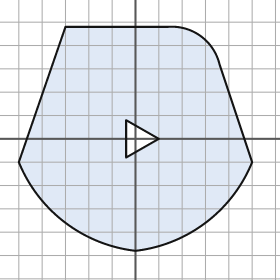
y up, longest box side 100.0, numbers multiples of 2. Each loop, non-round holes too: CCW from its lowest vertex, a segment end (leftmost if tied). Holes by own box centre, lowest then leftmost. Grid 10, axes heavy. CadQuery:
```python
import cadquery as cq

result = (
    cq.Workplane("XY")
    .moveTo(0.0, -48.0)
    .threePointArc((30.0, -36.0), (50.0, -10.0))
    .lineTo(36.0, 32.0)
    .threePointArc((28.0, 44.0), (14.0, 48.0))
    .lineTo(-30.0, 48.0)
    .lineTo(-50.0, -10.0)
    .threePointArc((-30.0, -36.0), (0.0, -48.0))
    .close()
    .moveTo(-4.0, -8.0)
    .lineTo(10.0, 0.0)
    .lineTo(-4.0, 8.0)
    .close()
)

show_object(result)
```